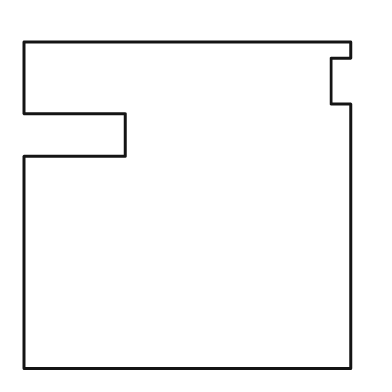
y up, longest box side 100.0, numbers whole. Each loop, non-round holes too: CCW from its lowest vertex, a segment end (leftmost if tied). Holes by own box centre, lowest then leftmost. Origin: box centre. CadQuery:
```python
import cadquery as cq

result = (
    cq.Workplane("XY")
    .moveTo(-50.0, -50.0)
    .lineTo(50.0, -50.0)
    .lineTo(50.0, 31.0)
    .lineTo(44.0, 31.0)
    .lineTo(44.0, 45.0)
    .lineTo(50.0, 45.0)
    .lineTo(50.0, 50.0)
    .lineTo(-50.0, 50.0)
    .lineTo(-50.0, 28.0)
    .lineTo(-19.0, 28.0)
    .lineTo(-19.0, 15.0)
    .lineTo(-50.0, 15.0)
    .close()
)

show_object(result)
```